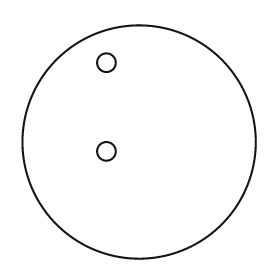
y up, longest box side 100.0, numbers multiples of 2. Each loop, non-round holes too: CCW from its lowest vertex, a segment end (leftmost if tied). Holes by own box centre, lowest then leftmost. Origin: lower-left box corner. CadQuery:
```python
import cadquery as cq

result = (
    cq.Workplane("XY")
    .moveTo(50.0, 50.0)
    .circle(50.0)
    .moveTo(36.0, 46.0)
    .circle(4.0)
    .moveTo(36.0, 84.0)
    .circle(4.0)
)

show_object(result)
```